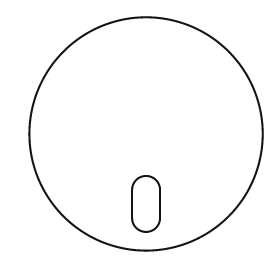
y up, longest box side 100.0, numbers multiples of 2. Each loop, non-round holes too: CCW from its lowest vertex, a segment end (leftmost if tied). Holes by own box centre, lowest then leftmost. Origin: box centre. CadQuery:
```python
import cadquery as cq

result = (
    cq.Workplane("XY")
    .moveTo(0.0, 0.0)
    .circle(50.0)
    .moveTo(-6.0, -36.0)
    .threePointArc((0.0, -42.0), (6.0, -36.0))
    .lineTo(6.0, -24.0)
    .threePointArc((0.0, -18.0), (-6.0, -24.0))
    .close()
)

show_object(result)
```